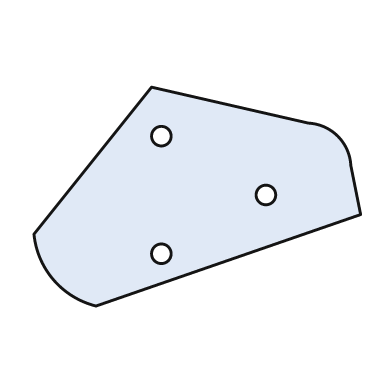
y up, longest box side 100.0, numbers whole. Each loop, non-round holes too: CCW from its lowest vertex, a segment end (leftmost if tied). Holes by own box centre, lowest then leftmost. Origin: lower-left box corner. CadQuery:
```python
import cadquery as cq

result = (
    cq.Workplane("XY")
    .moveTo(19.0, 0.0)
    .lineTo(100.0, 28.0)
    .lineTo(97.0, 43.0)
    .threePointArc((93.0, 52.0), (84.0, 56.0))
    .lineTo(36.0, 67.0)
    .lineTo(0.0, 22.0)
    .threePointArc((6.0, 8.0), (19.0, 0.0))
    .close()
    .moveTo(39.0, 16.0)
    .circle(3.0)
    .moveTo(71.0, 34.0)
    .circle(3.0)
    .moveTo(39.0, 52.0)
    .circle(3.0)
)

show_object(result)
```